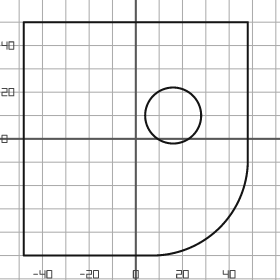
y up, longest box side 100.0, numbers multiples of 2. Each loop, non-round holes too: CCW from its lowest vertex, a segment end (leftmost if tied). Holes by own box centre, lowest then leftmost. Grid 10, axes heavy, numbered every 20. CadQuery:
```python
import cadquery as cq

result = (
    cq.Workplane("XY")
    .moveTo(-48.0, -50.0)
    .lineTo(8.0, -50.0)
    .threePointArc((36.0, -38.0), (48.0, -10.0))
    .lineTo(48.0, 50.0)
    .lineTo(-48.0, 50.0)
    .close()
    .moveTo(16.0, 10.0)
    .circle(12.0)
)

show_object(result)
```